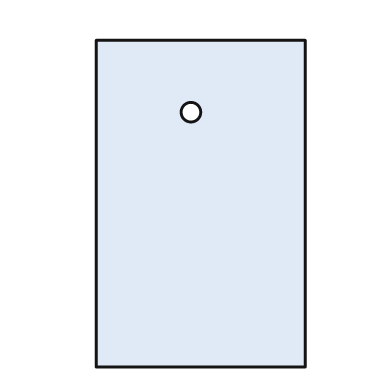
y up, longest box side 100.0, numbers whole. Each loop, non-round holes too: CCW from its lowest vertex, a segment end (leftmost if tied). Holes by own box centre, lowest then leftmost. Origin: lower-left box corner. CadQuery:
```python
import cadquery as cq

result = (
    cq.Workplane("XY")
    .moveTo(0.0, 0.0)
    .lineTo(64.0, 0.0)
    .lineTo(64.0, 100.0)
    .lineTo(0.0, 100.0)
    .close()
    .moveTo(29.0, 78.0)
    .circle(3.0)
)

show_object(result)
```